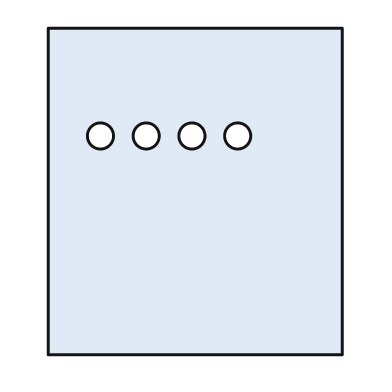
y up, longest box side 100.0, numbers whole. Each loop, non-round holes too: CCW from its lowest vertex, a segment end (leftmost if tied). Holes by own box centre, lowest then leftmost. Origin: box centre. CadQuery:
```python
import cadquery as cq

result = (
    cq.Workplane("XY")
    .moveTo(-45.0, -50.0)
    .lineTo(45.0, -50.0)
    .lineTo(45.0, 50.0)
    .lineTo(-45.0, 50.0)
    .close()
    .moveTo(-29.0, 17.0)
    .circle(4.0)
    .moveTo(-15.0, 17.0)
    .circle(4.0)
    .moveTo(-1.0, 17.0)
    .circle(4.0)
    .moveTo(13.0, 17.0)
    .circle(4.0)
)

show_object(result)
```